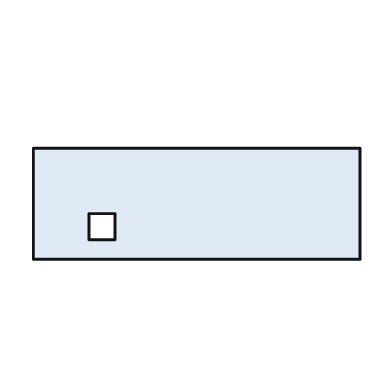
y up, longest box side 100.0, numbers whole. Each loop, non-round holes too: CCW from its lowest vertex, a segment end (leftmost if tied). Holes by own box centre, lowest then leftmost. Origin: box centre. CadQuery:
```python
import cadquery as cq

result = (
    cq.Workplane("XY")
    .moveTo(-50.0, -17.0)
    .lineTo(50.0, -17.0)
    .lineTo(50.0, 17.0)
    .lineTo(-50.0, 17.0)
    .close()
    .moveTo(-33.0, -11.0)
    .lineTo(-25.0, -11.0)
    .lineTo(-25.0, -3.0)
    .lineTo(-33.0, -3.0)
    .close()
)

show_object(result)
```